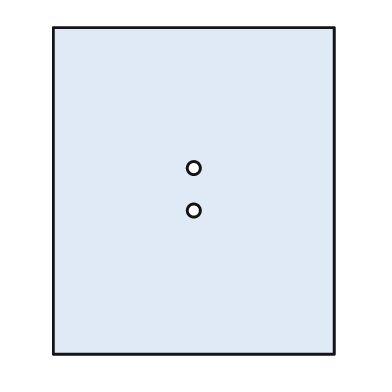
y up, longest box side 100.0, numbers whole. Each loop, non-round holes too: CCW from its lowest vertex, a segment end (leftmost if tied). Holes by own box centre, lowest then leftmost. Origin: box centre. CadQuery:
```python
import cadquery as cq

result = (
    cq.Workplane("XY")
    .moveTo(-43.0, -50.0)
    .lineTo(43.0, -50.0)
    .lineTo(43.0, 50.0)
    .lineTo(-43.0, 50.0)
    .close()
    .moveTo(0.0, -6.0)
    .circle(2.0)
    .moveTo(0.0, 7.0)
    .circle(2.0)
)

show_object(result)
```